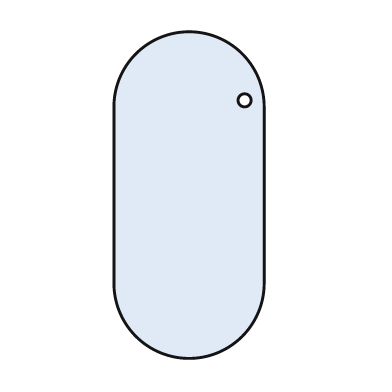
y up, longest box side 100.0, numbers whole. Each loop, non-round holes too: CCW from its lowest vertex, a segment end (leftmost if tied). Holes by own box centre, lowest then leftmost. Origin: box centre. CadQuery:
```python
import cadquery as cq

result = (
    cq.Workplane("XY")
    .moveTo(-23.0, -27.0)
    .threePointArc((0.0, -50.0), (23.0, -27.0))
    .lineTo(23.0, 27.0)
    .threePointArc((0.0, 50.0), (-23.0, 27.0))
    .close()
    .moveTo(17.0, 29.0)
    .circle(2.0)
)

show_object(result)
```